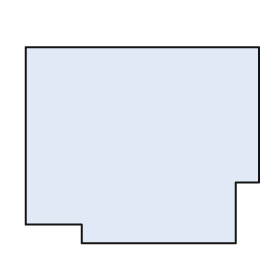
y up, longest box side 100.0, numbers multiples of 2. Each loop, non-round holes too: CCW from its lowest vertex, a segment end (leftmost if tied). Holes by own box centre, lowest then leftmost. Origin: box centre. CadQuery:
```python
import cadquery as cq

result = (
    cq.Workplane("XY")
    .moveTo(-26.0, -42.0)
    .lineTo(40.0, -42.0)
    .lineTo(40.0, -16.0)
    .lineTo(50.0, -16.0)
    .lineTo(50.0, 42.0)
    .lineTo(-50.0, 42.0)
    .lineTo(-50.0, -34.0)
    .lineTo(-26.0, -34.0)
    .close()
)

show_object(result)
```